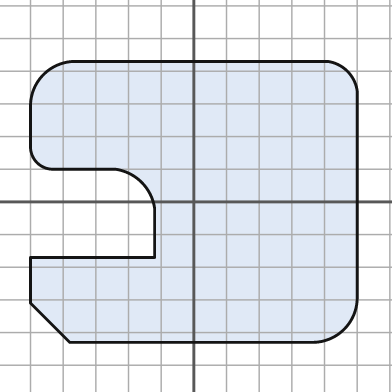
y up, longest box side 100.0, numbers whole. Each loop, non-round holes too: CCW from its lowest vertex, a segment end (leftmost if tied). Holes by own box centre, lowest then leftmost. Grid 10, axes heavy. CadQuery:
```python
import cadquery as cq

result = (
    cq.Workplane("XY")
    .moveTo(-38.0, -43.0)
    .lineTo(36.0, -43.0)
    .threePointArc((46.0, -39.0), (50.0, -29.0))
    .lineTo(50.0, 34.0)
    .threePointArc((47.0, 40.0), (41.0, 43.0))
    .lineTo(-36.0, 43.0)
    .threePointArc((-46.0, 39.0), (-50.0, 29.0))
    .lineTo(-50.0, 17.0)
    .threePointArc((-48.0, 12.0), (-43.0, 10.0))
    .lineTo(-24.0, 10.0)
    .threePointArc((-16.0, 6.0), (-12.0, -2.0))
    .lineTo(-12.0, -17.0)
    .lineTo(-50.0, -17.0)
    .lineTo(-50.0, -31.0)
    .close()
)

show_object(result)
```